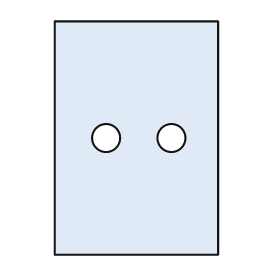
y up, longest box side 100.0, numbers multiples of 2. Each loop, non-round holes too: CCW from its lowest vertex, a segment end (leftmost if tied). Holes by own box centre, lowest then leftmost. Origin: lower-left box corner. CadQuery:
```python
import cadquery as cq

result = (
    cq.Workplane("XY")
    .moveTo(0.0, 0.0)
    .lineTo(70.0, 0.0)
    .lineTo(70.0, 100.0)
    .lineTo(0.0, 100.0)
    .close()
    .moveTo(22.0, 50.0)
    .circle(6.0)
    .moveTo(50.0, 50.0)
    .circle(6.0)
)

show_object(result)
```